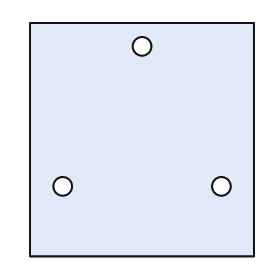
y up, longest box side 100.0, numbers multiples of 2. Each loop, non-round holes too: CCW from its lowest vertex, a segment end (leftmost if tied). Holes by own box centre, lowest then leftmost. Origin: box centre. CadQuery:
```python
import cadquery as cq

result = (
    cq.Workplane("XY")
    .moveTo(-48.0, -50.0)
    .lineTo(48.0, -50.0)
    .lineTo(48.0, 50.0)
    .lineTo(-48.0, 50.0)
    .close()
    .moveTo(-34.0, -20.0)
    .circle(4.0)
    .moveTo(34.0, -20.0)
    .circle(4.0)
    .moveTo(0.0, 40.0)
    .circle(4.0)
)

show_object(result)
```